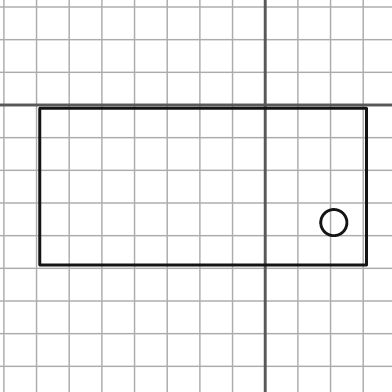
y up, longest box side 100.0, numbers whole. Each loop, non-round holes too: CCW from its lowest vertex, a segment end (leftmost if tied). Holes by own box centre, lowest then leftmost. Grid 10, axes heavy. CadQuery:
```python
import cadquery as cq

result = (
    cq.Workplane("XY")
    .moveTo(-69.0, -49.0)
    .lineTo(31.0, -49.0)
    .lineTo(31.0, -1.0)
    .lineTo(-69.0, -1.0)
    .close()
    .moveTo(21.0, -36.0)
    .circle(4.0)
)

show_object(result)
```